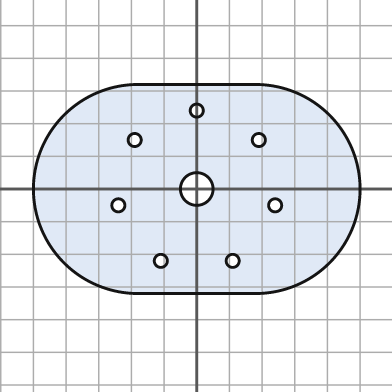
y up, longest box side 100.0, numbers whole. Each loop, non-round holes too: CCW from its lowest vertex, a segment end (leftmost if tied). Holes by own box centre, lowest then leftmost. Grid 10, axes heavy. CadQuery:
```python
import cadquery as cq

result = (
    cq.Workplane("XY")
    .moveTo(-18.0, -32.0)
    .lineTo(18.0, -32.0)
    .threePointArc((50.0, 0.0), (18.0, 32.0))
    .lineTo(-18.0, 32.0)
    .threePointArc((-50.0, 0.0), (-18.0, -32.0))
    .close()
    .moveTo(-11.0, -22.0)
    .circle(2.0)
    .moveTo(11.0, -22.0)
    .circle(2.0)
    .moveTo(-24.0, -5.0)
    .circle(2.0)
    .moveTo(24.0, -5.0)
    .circle(2.0)
    .moveTo(0.0, 0.0)
    .circle(5.0)
    .moveTo(-19.0, 15.0)
    .circle(2.0)
    .moveTo(19.0, 15.0)
    .circle(2.0)
    .moveTo(0.0, 24.0)
    .circle(2.0)
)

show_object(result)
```